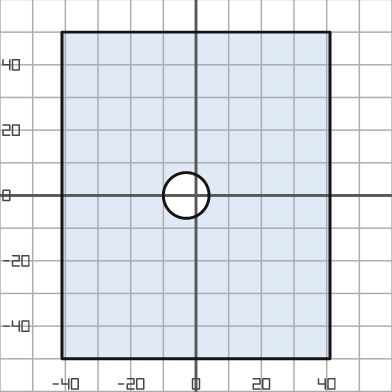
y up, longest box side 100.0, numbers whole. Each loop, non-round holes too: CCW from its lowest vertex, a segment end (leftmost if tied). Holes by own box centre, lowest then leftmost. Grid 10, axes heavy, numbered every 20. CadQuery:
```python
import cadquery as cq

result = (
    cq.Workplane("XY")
    .moveTo(-41.0, -50.0)
    .lineTo(41.0, -50.0)
    .lineTo(41.0, 50.0)
    .lineTo(-41.0, 50.0)
    .close()
    .moveTo(-3.0, 0.0)
    .circle(7.0)
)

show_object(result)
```